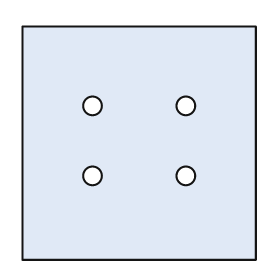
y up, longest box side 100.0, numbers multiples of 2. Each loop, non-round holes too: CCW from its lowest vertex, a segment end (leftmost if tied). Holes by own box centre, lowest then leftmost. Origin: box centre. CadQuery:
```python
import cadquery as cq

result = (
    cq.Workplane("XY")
    .moveTo(-50.0, -50.0)
    .lineTo(50.0, -50.0)
    .lineTo(50.0, 50.0)
    .lineTo(-50.0, 50.0)
    .close()
    .moveTo(-20.0, -14.0)
    .circle(4.0)
    .moveTo(20.0, -14.0)
    .circle(4.0)
    .moveTo(-20.0, 16.0)
    .circle(4.0)
    .moveTo(20.0, 16.0)
    .circle(4.0)
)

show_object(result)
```